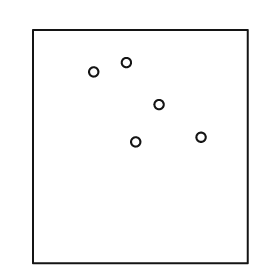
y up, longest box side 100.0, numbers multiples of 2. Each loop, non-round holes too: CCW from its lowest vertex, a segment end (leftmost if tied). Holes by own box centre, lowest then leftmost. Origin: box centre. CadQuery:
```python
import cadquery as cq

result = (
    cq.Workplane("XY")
    .moveTo(-46.0, -50.0)
    .lineTo(46.0, -50.0)
    .lineTo(46.0, 50.0)
    .lineTo(-46.0, 50.0)
    .close()
    .moveTo(-2.0, 2.0)
    .circle(2.0)
    .moveTo(26.0, 4.0)
    .circle(2.0)
    .moveTo(8.0, 18.0)
    .circle(2.0)
    .moveTo(-20.0, 32.0)
    .circle(2.0)
    .moveTo(-6.0, 36.0)
    .circle(2.0)
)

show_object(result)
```